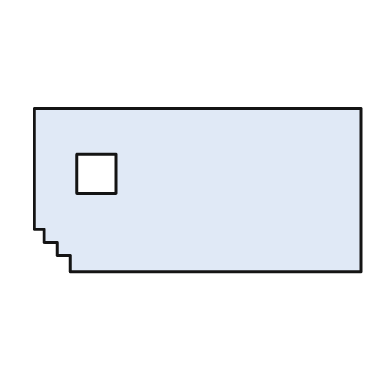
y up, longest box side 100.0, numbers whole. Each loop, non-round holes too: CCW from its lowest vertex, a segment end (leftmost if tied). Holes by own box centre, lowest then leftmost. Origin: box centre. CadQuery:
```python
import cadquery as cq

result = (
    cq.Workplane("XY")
    .moveTo(-39.0, -25.0)
    .lineTo(50.0, -25.0)
    .lineTo(50.0, 25.0)
    .lineTo(-50.0, 25.0)
    .lineTo(-50.0, -12.0)
    .lineTo(-47.0, -12.0)
    .lineTo(-47.0, -16.0)
    .lineTo(-43.0, -16.0)
    .lineTo(-43.0, -20.0)
    .lineTo(-39.0, -20.0)
    .close()
    .moveTo(-37.0, -1.0)
    .lineTo(-25.0, -1.0)
    .lineTo(-25.0, 11.0)
    .lineTo(-37.0, 11.0)
    .close()
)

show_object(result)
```